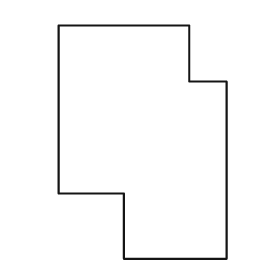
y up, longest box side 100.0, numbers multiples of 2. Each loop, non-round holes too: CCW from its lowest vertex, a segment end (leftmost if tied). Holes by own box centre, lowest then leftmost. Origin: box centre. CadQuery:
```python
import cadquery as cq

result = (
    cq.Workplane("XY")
    .moveTo(-8.0, -50.0)
    .lineTo(36.0, -50.0)
    .lineTo(36.0, 26.0)
    .lineTo(20.0, 26.0)
    .lineTo(20.0, 50.0)
    .lineTo(-36.0, 50.0)
    .lineTo(-36.0, -22.0)
    .lineTo(-8.0, -22.0)
    .close()
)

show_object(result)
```